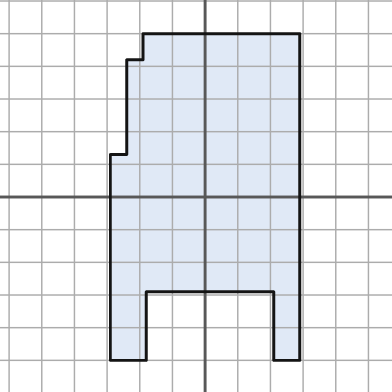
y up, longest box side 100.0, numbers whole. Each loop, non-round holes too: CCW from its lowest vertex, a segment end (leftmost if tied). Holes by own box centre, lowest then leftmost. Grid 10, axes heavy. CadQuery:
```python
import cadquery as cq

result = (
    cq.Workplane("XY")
    .moveTo(-29.0, -50.0)
    .lineTo(-18.0, -50.0)
    .lineTo(-18.0, -29.0)
    .lineTo(21.0, -29.0)
    .lineTo(21.0, -50.0)
    .lineTo(29.0, -50.0)
    .lineTo(29.0, 50.0)
    .lineTo(-19.0, 50.0)
    .lineTo(-19.0, 42.0)
    .lineTo(-24.0, 42.0)
    .lineTo(-24.0, 13.0)
    .lineTo(-29.0, 13.0)
    .close()
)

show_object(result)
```